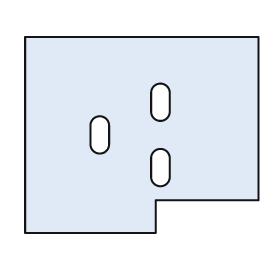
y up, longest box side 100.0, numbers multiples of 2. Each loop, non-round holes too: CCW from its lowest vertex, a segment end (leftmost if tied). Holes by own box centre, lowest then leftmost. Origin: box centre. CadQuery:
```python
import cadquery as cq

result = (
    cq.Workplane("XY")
    .moveTo(-50.0, -42.0)
    .lineTo(6.0, -42.0)
    .lineTo(6.0, -28.0)
    .lineTo(50.0, -28.0)
    .lineTo(50.0, 42.0)
    .lineTo(-50.0, 42.0)
    .close()
    .moveTo(4.0, -18.0)
    .threePointArc((8.0, -22.0), (12.0, -18.0))
    .lineTo(12.0, -10.0)
    .threePointArc((8.0, -6.0), (4.0, -10.0))
    .close()
    .moveTo(-22.0, -4.0)
    .threePointArc((-18.0, -8.0), (-14.0, -4.0))
    .lineTo(-14.0, 4.0)
    .threePointArc((-18.0, 8.0), (-22.0, 4.0))
    .close()
    .moveTo(4.0, 10.0)
    .threePointArc((8.0, 6.0), (12.0, 10.0))
    .lineTo(12.0, 18.0)
    .threePointArc((8.0, 22.0), (4.0, 18.0))
    .close()
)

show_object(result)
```